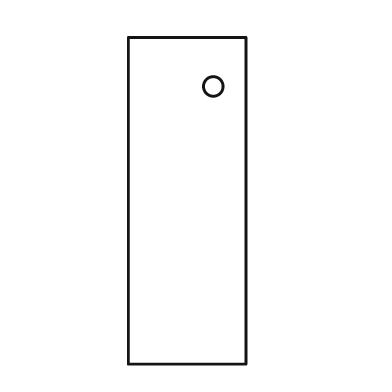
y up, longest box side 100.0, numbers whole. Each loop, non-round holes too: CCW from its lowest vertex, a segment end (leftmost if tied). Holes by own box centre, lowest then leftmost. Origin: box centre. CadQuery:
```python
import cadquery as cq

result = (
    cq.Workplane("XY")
    .moveTo(-18.0, -50.0)
    .lineTo(18.0, -50.0)
    .lineTo(18.0, 50.0)
    .lineTo(-18.0, 50.0)
    .close()
    .moveTo(8.0, 35.0)
    .circle(3.0)
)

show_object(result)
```